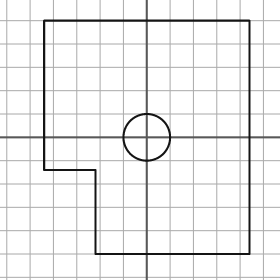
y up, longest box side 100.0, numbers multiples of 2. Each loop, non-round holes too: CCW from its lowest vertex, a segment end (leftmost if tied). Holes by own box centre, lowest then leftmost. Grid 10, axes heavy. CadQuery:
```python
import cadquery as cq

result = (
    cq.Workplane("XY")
    .moveTo(-22.0, -50.0)
    .lineTo(44.0, -50.0)
    .lineTo(44.0, 50.0)
    .lineTo(-44.0, 50.0)
    .lineTo(-44.0, -14.0)
    .lineTo(-22.0, -14.0)
    .close()
    .moveTo(0.0, 0.0)
    .circle(10.0)
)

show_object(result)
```